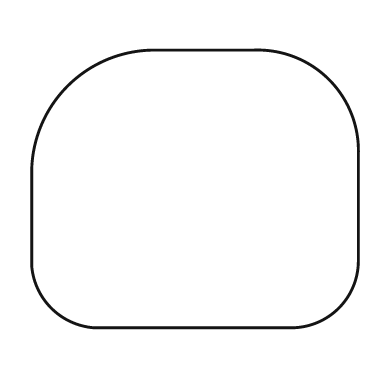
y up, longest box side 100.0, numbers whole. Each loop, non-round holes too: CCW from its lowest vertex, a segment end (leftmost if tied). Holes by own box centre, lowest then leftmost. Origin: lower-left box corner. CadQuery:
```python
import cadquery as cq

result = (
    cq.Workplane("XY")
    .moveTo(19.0, 0.0)
    .lineTo(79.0, 0.0)
    .threePointArc((94.0, 6.0), (100.0, 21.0))
    .lineTo(100.0, 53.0)
    .threePointArc((91.0, 76.0), (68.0, 85.0))
    .lineTo(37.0, 85.0)
    .threePointArc((11.0, 74.0), (0.0, 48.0))
    .lineTo(0.0, 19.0)
    .threePointArc((6.0, 6.0), (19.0, 0.0))
    .close()
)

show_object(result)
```